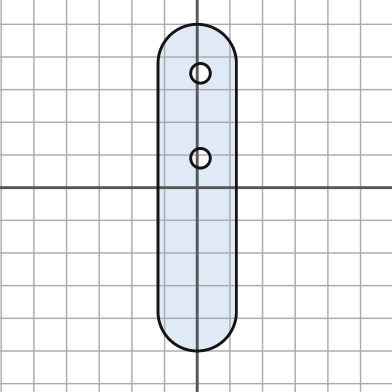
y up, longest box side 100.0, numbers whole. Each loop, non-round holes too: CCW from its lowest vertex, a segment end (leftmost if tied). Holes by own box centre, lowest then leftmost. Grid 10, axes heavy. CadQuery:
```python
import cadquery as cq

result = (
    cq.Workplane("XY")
    .moveTo(-12.0, -38.0)
    .threePointArc((0.0, -50.0), (12.0, -38.0))
    .lineTo(12.0, 38.0)
    .threePointArc((0.0, 50.0), (-12.0, 38.0))
    .close()
    .moveTo(1.0, 9.0)
    .circle(3.0)
    .moveTo(1.0, 35.0)
    .circle(3.0)
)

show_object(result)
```